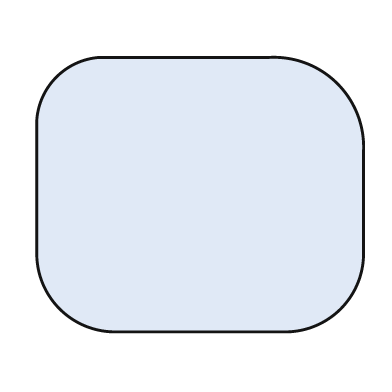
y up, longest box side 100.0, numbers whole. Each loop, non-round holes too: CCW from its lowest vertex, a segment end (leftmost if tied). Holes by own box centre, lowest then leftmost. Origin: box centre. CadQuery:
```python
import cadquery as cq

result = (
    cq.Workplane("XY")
    .moveTo(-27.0, -42.0)
    .lineTo(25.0, -42.0)
    .threePointArc((43.0, -35.0), (50.0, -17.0))
    .lineTo(50.0, 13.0)
    .threePointArc((42.0, 34.0), (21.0, 42.0))
    .lineTo(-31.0, 42.0)
    .threePointArc((-44.0, 36.0), (-50.0, 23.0))
    .lineTo(-50.0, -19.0)
    .threePointArc((-43.0, -35.0), (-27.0, -42.0))
    .close()
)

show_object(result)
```